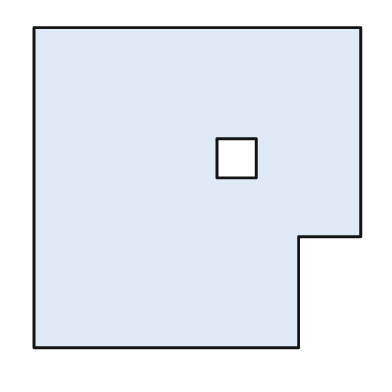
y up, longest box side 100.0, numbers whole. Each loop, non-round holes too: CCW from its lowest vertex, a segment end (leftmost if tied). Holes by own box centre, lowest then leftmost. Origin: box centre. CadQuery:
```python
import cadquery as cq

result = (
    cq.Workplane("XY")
    .moveTo(-50.0, -49.0)
    .lineTo(31.0, -49.0)
    .lineTo(31.0, -15.0)
    .lineTo(50.0, -15.0)
    .lineTo(50.0, 49.0)
    .lineTo(-50.0, 49.0)
    .close()
    .moveTo(6.0, 3.0)
    .lineTo(18.0, 3.0)
    .lineTo(18.0, 15.0)
    .lineTo(6.0, 15.0)
    .close()
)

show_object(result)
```